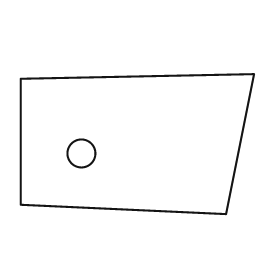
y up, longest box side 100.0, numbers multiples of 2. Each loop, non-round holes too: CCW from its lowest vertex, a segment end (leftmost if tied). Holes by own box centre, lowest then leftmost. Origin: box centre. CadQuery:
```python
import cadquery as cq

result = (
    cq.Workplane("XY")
    .moveTo(38.0, -30.0)
    .lineTo(50.0, 30.0)
    .lineTo(-50.0, 28.0)
    .lineTo(-50.0, -26.0)
    .close()
    .moveTo(-24.0, -4.0)
    .circle(6.0)
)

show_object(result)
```